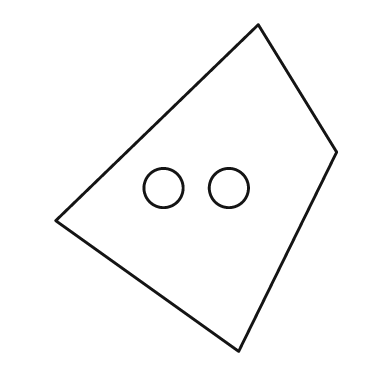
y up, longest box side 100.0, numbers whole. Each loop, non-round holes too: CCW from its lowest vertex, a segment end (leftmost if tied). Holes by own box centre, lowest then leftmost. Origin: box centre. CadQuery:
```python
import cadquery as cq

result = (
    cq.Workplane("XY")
    .moveTo(13.0, -50.0)
    .lineTo(43.0, 11.0)
    .lineTo(19.0, 50.0)
    .lineTo(-43.0, -10.0)
    .close()
    .moveTo(-10.0, 0.0)
    .circle(6.0)
    .moveTo(10.0, 0.0)
    .circle(6.0)
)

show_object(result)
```